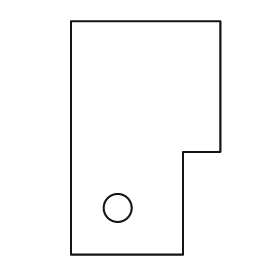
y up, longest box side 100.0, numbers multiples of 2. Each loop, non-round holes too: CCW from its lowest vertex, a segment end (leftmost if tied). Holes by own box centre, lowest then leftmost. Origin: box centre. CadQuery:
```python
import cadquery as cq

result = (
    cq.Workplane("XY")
    .moveTo(-32.0, -50.0)
    .lineTo(16.0, -50.0)
    .lineTo(16.0, -6.0)
    .lineTo(32.0, -6.0)
    .lineTo(32.0, 50.0)
    .lineTo(-32.0, 50.0)
    .close()
    .moveTo(-12.0, -30.0)
    .circle(6.0)
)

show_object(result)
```